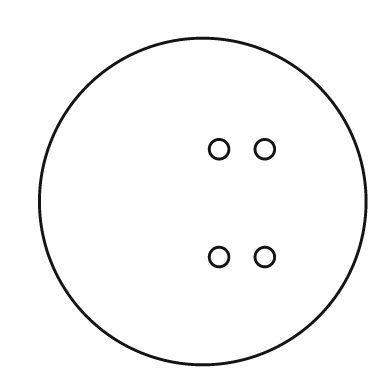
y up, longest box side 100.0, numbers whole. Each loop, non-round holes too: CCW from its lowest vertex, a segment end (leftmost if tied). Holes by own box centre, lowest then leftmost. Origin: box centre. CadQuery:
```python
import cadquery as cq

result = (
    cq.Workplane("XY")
    .moveTo(0.0, 0.0)
    .circle(50.0)
    .moveTo(5.0, -17.0)
    .circle(3.0)
    .moveTo(19.0, -17.0)
    .circle(3.0)
    .moveTo(5.0, 16.0)
    .circle(3.0)
    .moveTo(19.0, 16.0)
    .circle(3.0)
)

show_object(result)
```